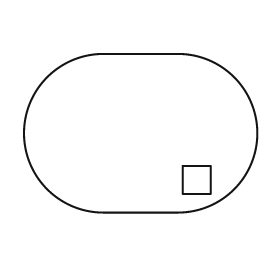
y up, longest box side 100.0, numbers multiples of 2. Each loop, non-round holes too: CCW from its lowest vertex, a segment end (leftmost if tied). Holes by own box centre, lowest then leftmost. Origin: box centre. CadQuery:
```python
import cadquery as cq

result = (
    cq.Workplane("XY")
    .moveTo(-16.0, -34.0)
    .lineTo(16.0, -34.0)
    .threePointArc((50.0, 0.0), (16.0, 34.0))
    .lineTo(-16.0, 34.0)
    .threePointArc((-50.0, 0.0), (-16.0, -34.0))
    .close()
    .moveTo(18.0, -26.0)
    .lineTo(30.0, -26.0)
    .lineTo(30.0, -14.0)
    .lineTo(18.0, -14.0)
    .close()
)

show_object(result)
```